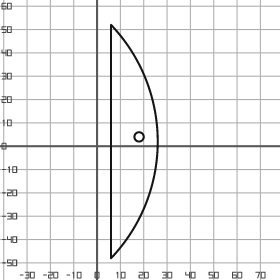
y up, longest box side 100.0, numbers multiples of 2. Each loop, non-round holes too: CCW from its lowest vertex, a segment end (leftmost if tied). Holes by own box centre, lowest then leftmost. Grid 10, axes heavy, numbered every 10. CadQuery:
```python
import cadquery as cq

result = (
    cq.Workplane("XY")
    .moveTo(6.0, -48.0)
    .threePointArc((26.0, 2.0), (6.0, 52.0))
    .close()
    .moveTo(18.0, 4.0)
    .circle(2.0)
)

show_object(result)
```